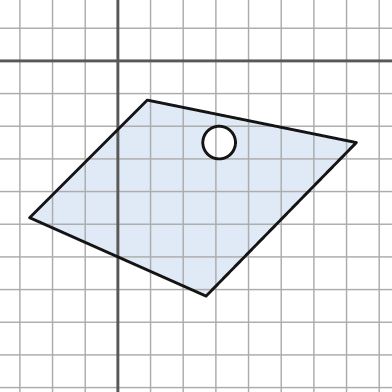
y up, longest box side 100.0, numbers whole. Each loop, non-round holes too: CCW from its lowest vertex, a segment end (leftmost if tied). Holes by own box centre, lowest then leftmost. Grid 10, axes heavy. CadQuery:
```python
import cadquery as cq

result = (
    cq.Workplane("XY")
    .moveTo(27.0, -72.0)
    .lineTo(73.0, -25.0)
    .lineTo(9.0, -12.0)
    .lineTo(-27.0, -48.0)
    .close()
    .moveTo(31.0, -25.0)
    .circle(5.0)
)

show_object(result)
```